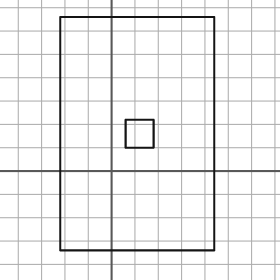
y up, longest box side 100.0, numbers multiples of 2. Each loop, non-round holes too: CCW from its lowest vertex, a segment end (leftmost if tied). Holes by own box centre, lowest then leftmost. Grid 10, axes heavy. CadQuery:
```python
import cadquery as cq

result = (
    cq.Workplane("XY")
    .moveTo(-22.0, -34.0)
    .lineTo(44.0, -34.0)
    .lineTo(44.0, 66.0)
    .lineTo(-22.0, 66.0)
    .close()
    .moveTo(6.0, 10.0)
    .lineTo(18.0, 10.0)
    .lineTo(18.0, 22.0)
    .lineTo(6.0, 22.0)
    .close()
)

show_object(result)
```